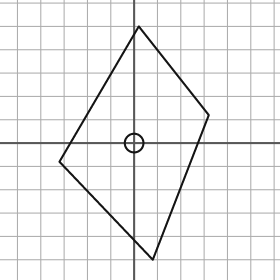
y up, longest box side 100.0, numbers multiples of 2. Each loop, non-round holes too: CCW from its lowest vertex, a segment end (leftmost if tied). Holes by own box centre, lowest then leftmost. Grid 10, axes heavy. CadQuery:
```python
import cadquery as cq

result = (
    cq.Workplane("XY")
    .moveTo(8.0, -50.0)
    .lineTo(32.0, 12.0)
    .lineTo(2.0, 50.0)
    .lineTo(-32.0, -8.0)
    .close()
    .moveTo(0.0, 0.0)
    .circle(4.0)
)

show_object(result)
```